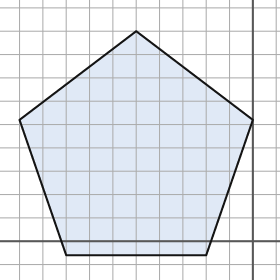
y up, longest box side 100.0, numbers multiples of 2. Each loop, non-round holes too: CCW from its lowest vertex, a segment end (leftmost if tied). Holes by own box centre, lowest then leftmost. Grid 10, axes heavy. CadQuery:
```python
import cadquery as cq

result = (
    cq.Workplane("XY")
    .moveTo(-80.0, -6.0)
    .lineTo(-20.0, -6.0)
    .lineTo(0.0, 52.0)
    .lineTo(-50.0, 90.0)
    .lineTo(-100.0, 52.0)
    .close()
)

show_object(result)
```